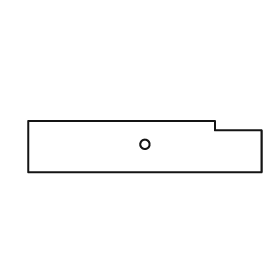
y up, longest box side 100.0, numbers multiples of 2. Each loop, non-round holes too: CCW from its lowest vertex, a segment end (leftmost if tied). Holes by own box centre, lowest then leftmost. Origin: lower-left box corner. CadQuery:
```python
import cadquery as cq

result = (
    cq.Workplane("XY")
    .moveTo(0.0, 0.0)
    .lineTo(100.0, 0.0)
    .lineTo(100.0, 18.0)
    .lineTo(80.0, 18.0)
    .lineTo(80.0, 22.0)
    .lineTo(0.0, 22.0)
    .close()
    .moveTo(50.0, 12.0)
    .circle(2.0)
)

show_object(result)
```